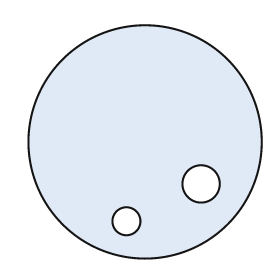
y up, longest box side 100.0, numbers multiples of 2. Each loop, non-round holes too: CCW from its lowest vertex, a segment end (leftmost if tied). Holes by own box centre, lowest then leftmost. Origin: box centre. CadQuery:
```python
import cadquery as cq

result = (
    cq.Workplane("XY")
    .moveTo(0.0, 0.0)
    .circle(50.0)
    .moveTo(-8.0, -34.0)
    .circle(6.0)
    .moveTo(24.0, -18.0)
    .circle(8.0)
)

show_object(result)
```